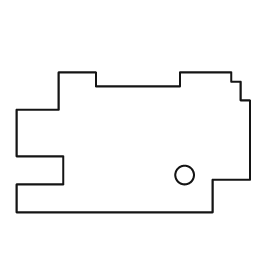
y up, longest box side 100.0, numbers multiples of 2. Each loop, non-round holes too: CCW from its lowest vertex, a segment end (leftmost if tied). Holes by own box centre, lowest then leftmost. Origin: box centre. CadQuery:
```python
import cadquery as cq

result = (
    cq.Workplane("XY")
    .moveTo(-50.0, -30.0)
    .lineTo(34.0, -30.0)
    .lineTo(34.0, -16.0)
    .lineTo(50.0, -16.0)
    .lineTo(50.0, 18.0)
    .lineTo(46.0, 18.0)
    .lineTo(46.0, 26.0)
    .lineTo(42.0, 26.0)
    .lineTo(42.0, 30.0)
    .lineTo(20.0, 30.0)
    .lineTo(20.0, 24.0)
    .lineTo(-16.0, 24.0)
    .lineTo(-16.0, 30.0)
    .lineTo(-32.0, 30.0)
    .lineTo(-32.0, 14.0)
    .lineTo(-50.0, 14.0)
    .lineTo(-50.0, -6.0)
    .lineTo(-30.0, -6.0)
    .lineTo(-30.0, -18.0)
    .lineTo(-50.0, -18.0)
    .close()
    .moveTo(22.0, -14.0)
    .circle(4.0)
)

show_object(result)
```